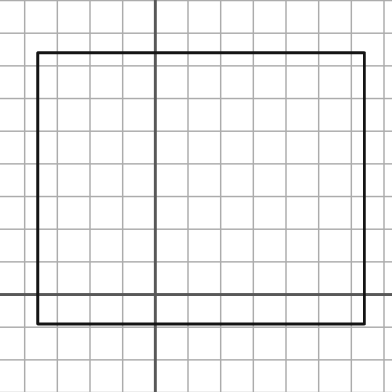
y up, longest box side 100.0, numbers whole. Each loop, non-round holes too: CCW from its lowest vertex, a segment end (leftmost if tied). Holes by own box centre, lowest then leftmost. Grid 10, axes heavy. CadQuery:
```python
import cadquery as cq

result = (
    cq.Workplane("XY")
    .moveTo(-36.0, -9.0)
    .lineTo(64.0, -9.0)
    .lineTo(64.0, 74.0)
    .lineTo(-36.0, 74.0)
    .close()
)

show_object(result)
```